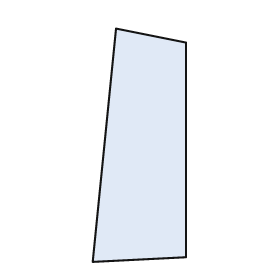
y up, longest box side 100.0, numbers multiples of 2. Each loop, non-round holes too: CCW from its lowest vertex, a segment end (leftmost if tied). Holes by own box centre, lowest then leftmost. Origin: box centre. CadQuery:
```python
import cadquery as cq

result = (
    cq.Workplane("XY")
    .moveTo(-20.0, -50.0)
    .lineTo(20.0, -48.0)
    .lineTo(20.0, 44.0)
    .lineTo(-10.0, 50.0)
    .close()
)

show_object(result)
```